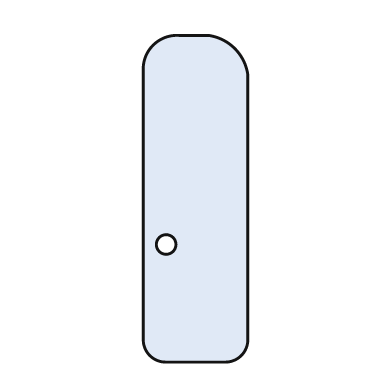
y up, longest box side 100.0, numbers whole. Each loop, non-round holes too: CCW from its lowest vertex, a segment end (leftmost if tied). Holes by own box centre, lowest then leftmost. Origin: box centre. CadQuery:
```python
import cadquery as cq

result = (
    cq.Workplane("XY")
    .moveTo(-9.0, -50.0)
    .lineTo(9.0, -50.0)
    .threePointArc((14.0, -48.0), (16.0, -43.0))
    .lineTo(16.0, 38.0)
    .threePointArc((12.0, 46.0), (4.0, 50.0))
    .lineTo(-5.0, 50.0)
    .threePointArc((-13.0, 47.0), (-16.0, 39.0))
    .lineTo(-16.0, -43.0)
    .threePointArc((-14.0, -48.0), (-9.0, -50.0))
    .close()
    .moveTo(-9.0, -14.0)
    .circle(3.0)
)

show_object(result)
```